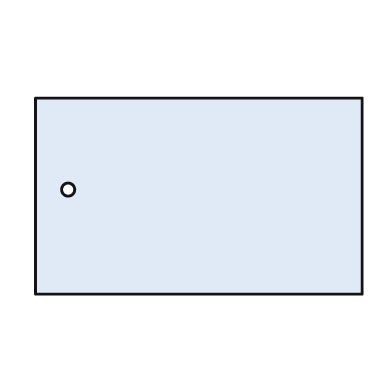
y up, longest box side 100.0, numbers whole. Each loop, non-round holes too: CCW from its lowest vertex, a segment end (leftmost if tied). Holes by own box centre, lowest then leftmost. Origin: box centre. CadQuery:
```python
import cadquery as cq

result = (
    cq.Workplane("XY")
    .moveTo(-50.0, -30.0)
    .lineTo(50.0, -30.0)
    .lineTo(50.0, 30.0)
    .lineTo(-50.0, 30.0)
    .close()
    .moveTo(-40.0, 2.0)
    .circle(2.0)
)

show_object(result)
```